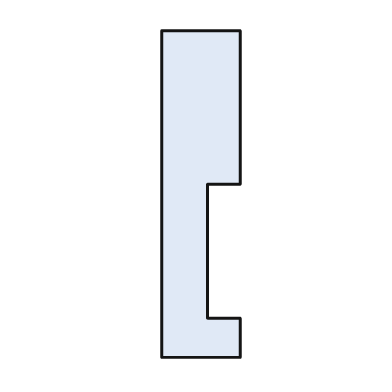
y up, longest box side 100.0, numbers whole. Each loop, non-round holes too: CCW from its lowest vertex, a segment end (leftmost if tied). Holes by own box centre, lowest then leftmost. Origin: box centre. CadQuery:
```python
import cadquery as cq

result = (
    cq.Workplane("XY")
    .moveTo(-12.0, -50.0)
    .lineTo(12.0, -50.0)
    .lineTo(12.0, -38.0)
    .lineTo(2.0, -38.0)
    .lineTo(2.0, 3.0)
    .lineTo(12.0, 3.0)
    .lineTo(12.0, 50.0)
    .lineTo(-12.0, 50.0)
    .close()
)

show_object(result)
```